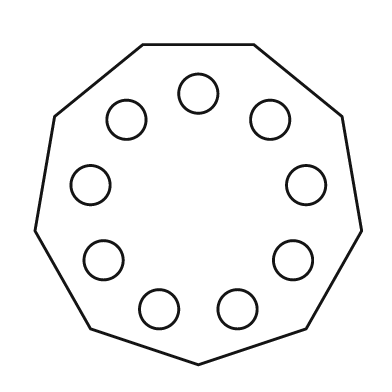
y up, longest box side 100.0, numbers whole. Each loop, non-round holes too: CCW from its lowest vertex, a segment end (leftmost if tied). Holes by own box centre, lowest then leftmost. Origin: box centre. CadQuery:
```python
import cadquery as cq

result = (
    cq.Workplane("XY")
    .moveTo(0.0, -49.0)
    .lineTo(33.0, -38.0)
    .lineTo(50.0, -8.0)
    .lineTo(44.0, 27.0)
    .lineTo(17.0, 49.0)
    .lineTo(-17.0, 49.0)
    .lineTo(-44.0, 27.0)
    .lineTo(-50.0, -8.0)
    .lineTo(-33.0, -38.0)
    .close()
    .moveTo(-12.0, -32.0)
    .circle(6.0)
    .moveTo(12.0, -32.0)
    .circle(6.0)
    .moveTo(-29.0, -17.0)
    .circle(6.0)
    .moveTo(29.0, -17.0)
    .circle(6.0)
    .moveTo(-33.0, 6.0)
    .circle(6.0)
    .moveTo(33.0, 6.0)
    .circle(6.0)
    .moveTo(-22.0, 26.0)
    .circle(6.0)
    .moveTo(22.0, 26.0)
    .circle(6.0)
    .moveTo(0.0, 34.0)
    .circle(6.0)
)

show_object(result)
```